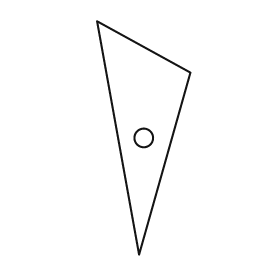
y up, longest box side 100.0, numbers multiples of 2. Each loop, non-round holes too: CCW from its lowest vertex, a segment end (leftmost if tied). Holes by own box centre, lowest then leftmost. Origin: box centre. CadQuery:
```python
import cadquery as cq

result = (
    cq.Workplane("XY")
    .moveTo(-2.0, -50.0)
    .lineTo(20.0, 28.0)
    .lineTo(-20.0, 50.0)
    .close()
    .moveTo(0.0, 0.0)
    .circle(4.0)
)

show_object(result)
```